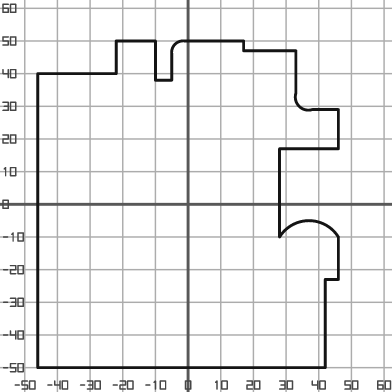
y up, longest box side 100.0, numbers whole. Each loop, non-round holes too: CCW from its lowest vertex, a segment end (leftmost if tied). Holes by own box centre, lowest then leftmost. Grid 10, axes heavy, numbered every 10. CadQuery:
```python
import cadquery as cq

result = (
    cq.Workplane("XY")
    .moveTo(-46.0, -50.0)
    .lineTo(42.0, -50.0)
    .lineTo(42.0, -23.0)
    .lineTo(46.0, -23.0)
    .lineTo(46.0, -10.0)
    .threePointArc((37.0, -5.0), (28.0, -10.0))
    .lineTo(28.0, 17.0)
    .lineTo(46.0, 17.0)
    .lineTo(46.0, 29.0)
    .lineTo(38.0, 29.0)
    .threePointArc((34.0, 30.0), (33.0, 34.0))
    .lineTo(33.0, 47.0)
    .lineTo(17.0, 47.0)
    .lineTo(17.0, 50.0)
    .lineTo(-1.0, 50.0)
    .threePointArc((-4.0, 49.0), (-5.0, 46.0))
    .lineTo(-5.0, 38.0)
    .lineTo(-10.0, 38.0)
    .lineTo(-10.0, 50.0)
    .lineTo(-22.0, 50.0)
    .lineTo(-22.0, 40.0)
    .lineTo(-46.0, 40.0)
    .close()
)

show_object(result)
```